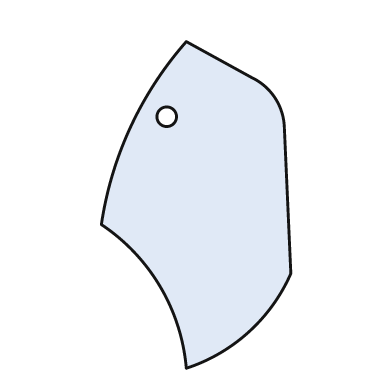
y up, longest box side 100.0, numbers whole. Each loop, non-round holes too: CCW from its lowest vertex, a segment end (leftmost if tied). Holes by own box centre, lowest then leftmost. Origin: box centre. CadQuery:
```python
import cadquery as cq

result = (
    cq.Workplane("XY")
    .moveTo(-3.0, -50.0)
    .threePointArc((16.0, -39.0), (29.0, -21.0))
    .lineTo(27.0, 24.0)
    .threePointArc((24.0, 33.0), (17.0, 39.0))
    .lineTo(-3.0, 50.0)
    .threePointArc((-20.0, 24.0), (-29.0, -6.0))
    .threePointArc((-11.0, -25.0), (-3.0, -50.0))
    .close()
    .moveTo(-9.0, 27.0)
    .circle(3.0)
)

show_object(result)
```